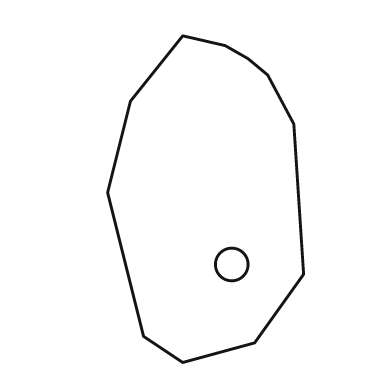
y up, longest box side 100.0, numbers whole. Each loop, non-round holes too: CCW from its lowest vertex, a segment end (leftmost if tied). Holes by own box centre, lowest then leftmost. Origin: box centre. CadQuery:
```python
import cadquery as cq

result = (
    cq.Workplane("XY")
    .moveTo(-7.0, -50.0)
    .lineTo(15.0, -44.0)
    .lineTo(30.0, -23.0)
    .lineTo(27.0, 23.0)
    .lineTo(19.0, 38.0)
    .lineTo(13.0, 43.0)
    .lineTo(6.0, 47.0)
    .lineTo(-7.0, 50.0)
    .lineTo(-23.0, 30.0)
    .lineTo(-30.0, 2.0)
    .lineTo(-19.0, -42.0)
    .close()
    .moveTo(8.0, -20.0)
    .circle(5.0)
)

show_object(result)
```